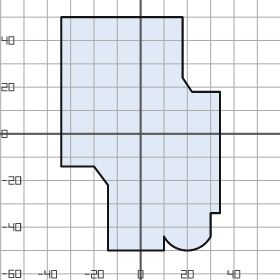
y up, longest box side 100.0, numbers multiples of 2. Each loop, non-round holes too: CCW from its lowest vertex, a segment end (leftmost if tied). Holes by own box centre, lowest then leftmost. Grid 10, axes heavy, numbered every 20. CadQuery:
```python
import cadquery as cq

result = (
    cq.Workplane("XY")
    .moveTo(-14.0, -50.0)
    .lineTo(10.0, -50.0)
    .lineTo(10.0, -44.0)
    .threePointArc((20.0, -50.0), (30.0, -44.0))
    .lineTo(30.0, -34.0)
    .lineTo(34.0, -34.0)
    .lineTo(34.0, 18.0)
    .lineTo(22.0, 18.0)
    .lineTo(18.0, 24.0)
    .lineTo(18.0, 50.0)
    .lineTo(-34.0, 50.0)
    .lineTo(-34.0, -14.0)
    .lineTo(-20.0, -14.0)
    .lineTo(-14.0, -22.0)
    .close()
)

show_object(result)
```